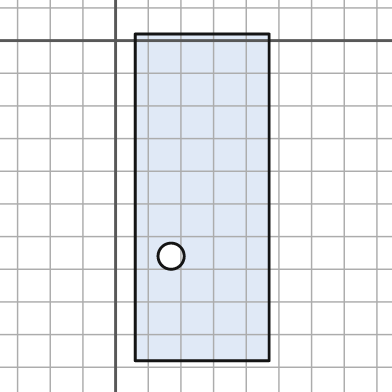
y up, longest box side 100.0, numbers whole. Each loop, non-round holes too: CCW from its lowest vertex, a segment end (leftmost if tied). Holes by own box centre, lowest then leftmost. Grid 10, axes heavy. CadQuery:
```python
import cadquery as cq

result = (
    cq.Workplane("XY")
    .moveTo(6.0, -98.0)
    .lineTo(47.0, -98.0)
    .lineTo(47.0, 2.0)
    .lineTo(6.0, 2.0)
    .close()
    .moveTo(17.0, -66.0)
    .circle(4.0)
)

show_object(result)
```